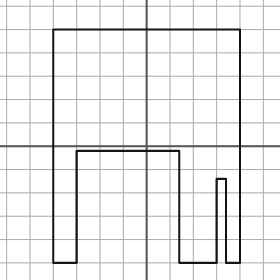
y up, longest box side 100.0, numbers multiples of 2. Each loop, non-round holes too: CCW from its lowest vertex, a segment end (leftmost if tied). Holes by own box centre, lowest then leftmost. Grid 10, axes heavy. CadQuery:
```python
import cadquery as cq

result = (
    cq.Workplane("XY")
    .moveTo(-40.0, -50.0)
    .lineTo(-30.0, -50.0)
    .lineTo(-30.0, -2.0)
    .lineTo(14.0, -2.0)
    .lineTo(14.0, -50.0)
    .lineTo(30.0, -50.0)
    .lineTo(30.0, -14.0)
    .lineTo(34.0, -14.0)
    .lineTo(34.0, -50.0)
    .lineTo(40.0, -50.0)
    .lineTo(40.0, 50.0)
    .lineTo(-40.0, 50.0)
    .close()
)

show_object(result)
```